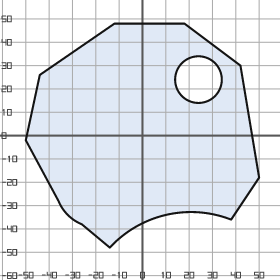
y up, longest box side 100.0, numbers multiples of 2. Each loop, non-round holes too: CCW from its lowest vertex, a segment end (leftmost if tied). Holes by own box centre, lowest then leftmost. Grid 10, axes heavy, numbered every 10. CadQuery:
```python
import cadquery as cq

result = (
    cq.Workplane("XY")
    .moveTo(-14.0, -48.0)
    .threePointArc((10.0, -34.0), (38.0, -36.0))
    .lineTo(50.0, -18.0)
    .lineTo(42.0, 30.0)
    .lineTo(18.0, 48.0)
    .lineTo(-12.0, 48.0)
    .lineTo(-44.0, 26.0)
    .lineTo(-50.0, -2.0)
    .lineTo(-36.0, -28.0)
    .threePointArc((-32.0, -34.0), (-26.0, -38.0))
    .close()
    .moveTo(24.0, 24.0)
    .circle(10.0)
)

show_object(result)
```